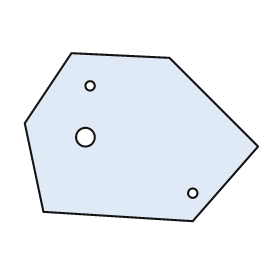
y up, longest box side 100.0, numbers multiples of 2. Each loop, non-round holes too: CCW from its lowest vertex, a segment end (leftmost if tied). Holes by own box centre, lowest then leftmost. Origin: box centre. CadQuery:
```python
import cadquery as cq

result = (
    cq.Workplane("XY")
    .moveTo(22.0, -36.0)
    .lineTo(50.0, -4.0)
    .lineTo(12.0, 34.0)
    .lineTo(-30.0, 36.0)
    .lineTo(-50.0, 6.0)
    .lineTo(-42.0, -32.0)
    .close()
    .moveTo(22.0, -24.0)
    .circle(2.0)
    .moveTo(-24.0, 0.0)
    .circle(4.0)
    .moveTo(-22.0, 22.0)
    .circle(2.0)
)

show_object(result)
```